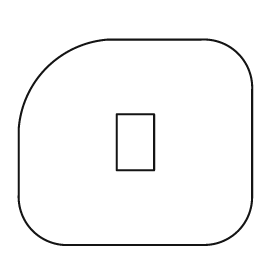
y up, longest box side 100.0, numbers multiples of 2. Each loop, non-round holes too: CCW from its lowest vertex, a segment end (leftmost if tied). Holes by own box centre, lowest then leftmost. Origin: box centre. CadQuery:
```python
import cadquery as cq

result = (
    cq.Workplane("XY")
    .moveTo(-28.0, -44.0)
    .lineTo(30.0, -44.0)
    .threePointArc((44.0, -38.0), (50.0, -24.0))
    .lineTo(50.0, 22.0)
    .threePointArc((44.0, 38.0), (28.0, 44.0))
    .lineTo(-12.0, 44.0)
    .threePointArc((-38.0, 32.0), (-50.0, 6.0))
    .lineTo(-50.0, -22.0)
    .threePointArc((-44.0, -38.0), (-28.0, -44.0))
    .close()
    .moveTo(-8.0, -12.0)
    .lineTo(8.0, -12.0)
    .lineTo(8.0, 12.0)
    .lineTo(-8.0, 12.0)
    .close()
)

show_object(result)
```